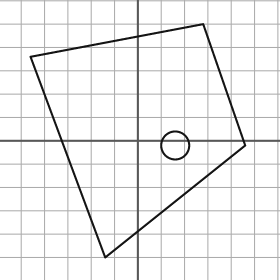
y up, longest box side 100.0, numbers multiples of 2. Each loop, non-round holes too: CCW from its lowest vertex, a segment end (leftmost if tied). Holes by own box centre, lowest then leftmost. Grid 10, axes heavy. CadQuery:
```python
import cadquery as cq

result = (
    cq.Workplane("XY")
    .moveTo(-14.0, -50.0)
    .lineTo(46.0, -2.0)
    .lineTo(28.0, 50.0)
    .lineTo(-46.0, 36.0)
    .close()
    .moveTo(16.0, -2.0)
    .circle(6.0)
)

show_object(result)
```